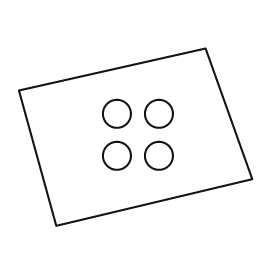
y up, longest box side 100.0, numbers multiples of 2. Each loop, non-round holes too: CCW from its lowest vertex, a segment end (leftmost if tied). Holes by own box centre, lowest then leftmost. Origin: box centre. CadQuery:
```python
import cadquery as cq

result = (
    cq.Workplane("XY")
    .moveTo(-34.0, -38.0)
    .lineTo(50.0, -18.0)
    .lineTo(30.0, 38.0)
    .lineTo(-50.0, 20.0)
    .close()
    .moveTo(-8.0, -8.0)
    .circle(6.0)
    .moveTo(10.0, -8.0)
    .circle(6.0)
    .moveTo(-8.0, 10.0)
    .circle(6.0)
    .moveTo(10.0, 10.0)
    .circle(6.0)
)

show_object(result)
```